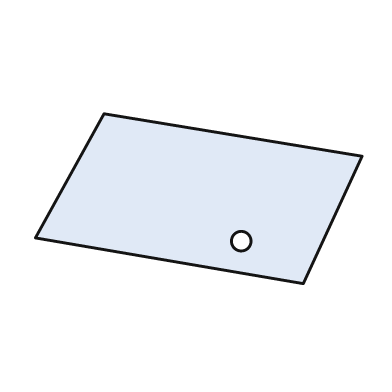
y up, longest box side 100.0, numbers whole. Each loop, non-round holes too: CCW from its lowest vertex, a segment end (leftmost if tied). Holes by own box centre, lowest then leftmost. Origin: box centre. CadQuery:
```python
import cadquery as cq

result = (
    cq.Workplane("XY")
    .moveTo(32.0, -26.0)
    .lineTo(50.0, 13.0)
    .lineTo(-29.0, 26.0)
    .lineTo(-50.0, -12.0)
    .close()
    .moveTo(13.0, -13.0)
    .circle(3.0)
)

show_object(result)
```